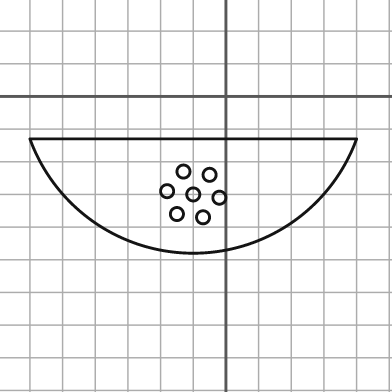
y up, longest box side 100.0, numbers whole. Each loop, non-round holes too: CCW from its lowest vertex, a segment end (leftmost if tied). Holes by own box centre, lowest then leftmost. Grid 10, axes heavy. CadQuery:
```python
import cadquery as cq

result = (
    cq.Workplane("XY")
    .moveTo(-60.0, -13.0)
    .threePointArc((-10.0, -48.0), (40.0, -13.0))
    .close()
    .moveTo(-7.0, -37.0)
    .circle(2.0)
    .moveTo(-15.0, -36.0)
    .circle(2.0)
    .moveTo(-2.0, -31.0)
    .circle(2.0)
    .moveTo(-10.0, -30.0)
    .circle(2.0)
    .moveTo(-18.0, -29.0)
    .circle(2.0)
    .moveTo(-5.0, -24.0)
    .circle(2.0)
    .moveTo(-13.0, -23.0)
    .circle(2.0)
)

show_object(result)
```